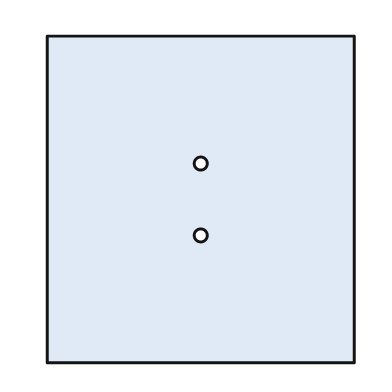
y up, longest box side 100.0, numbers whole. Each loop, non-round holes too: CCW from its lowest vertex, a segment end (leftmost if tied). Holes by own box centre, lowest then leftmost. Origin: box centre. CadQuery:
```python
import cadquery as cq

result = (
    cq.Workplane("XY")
    .moveTo(-47.0, -50.0)
    .lineTo(47.0, -50.0)
    .lineTo(47.0, 50.0)
    .lineTo(-47.0, 50.0)
    .close()
    .moveTo(0.0, -11.0)
    .circle(2.0)
    .moveTo(0.0, 11.0)
    .circle(2.0)
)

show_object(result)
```